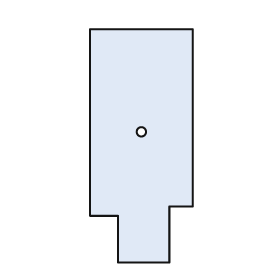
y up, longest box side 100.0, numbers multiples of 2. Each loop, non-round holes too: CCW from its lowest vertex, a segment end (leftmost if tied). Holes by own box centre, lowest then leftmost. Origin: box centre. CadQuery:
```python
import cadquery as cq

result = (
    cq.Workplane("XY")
    .moveTo(-10.0, -50.0)
    .lineTo(12.0, -50.0)
    .lineTo(12.0, -26.0)
    .lineTo(22.0, -26.0)
    .lineTo(22.0, 50.0)
    .lineTo(-22.0, 50.0)
    .lineTo(-22.0, -30.0)
    .lineTo(-10.0, -30.0)
    .close()
    .moveTo(0.0, 6.0)
    .circle(2.0)
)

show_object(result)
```